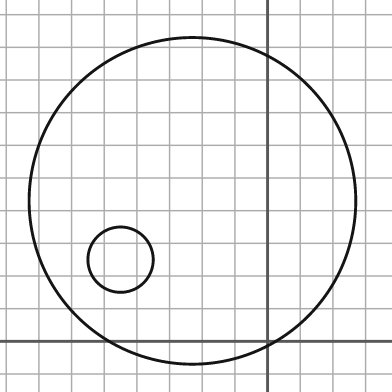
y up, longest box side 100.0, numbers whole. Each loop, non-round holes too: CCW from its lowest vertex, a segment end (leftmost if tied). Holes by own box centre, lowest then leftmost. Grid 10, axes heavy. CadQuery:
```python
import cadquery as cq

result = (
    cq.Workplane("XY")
    .moveTo(-23.0, 43.0)
    .circle(50.0)
    .moveTo(-45.0, 25.0)
    .circle(10.0)
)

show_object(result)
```